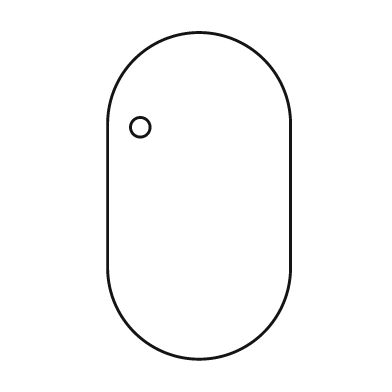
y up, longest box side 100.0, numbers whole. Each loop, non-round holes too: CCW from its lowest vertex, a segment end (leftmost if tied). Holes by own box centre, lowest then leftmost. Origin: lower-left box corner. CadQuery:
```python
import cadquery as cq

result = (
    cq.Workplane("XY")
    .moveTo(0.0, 28.0)
    .threePointArc((28.0, 0.0), (56.0, 28.0))
    .lineTo(56.0, 72.0)
    .threePointArc((28.0, 100.0), (0.0, 72.0))
    .close()
    .moveTo(10.0, 71.0)
    .circle(3.0)
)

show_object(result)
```